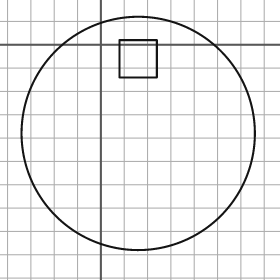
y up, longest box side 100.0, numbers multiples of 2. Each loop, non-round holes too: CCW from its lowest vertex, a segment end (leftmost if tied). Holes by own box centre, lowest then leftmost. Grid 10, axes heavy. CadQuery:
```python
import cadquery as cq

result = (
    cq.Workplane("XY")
    .moveTo(16.0, -38.0)
    .circle(50.0)
    .moveTo(8.0, -14.0)
    .lineTo(24.0, -14.0)
    .lineTo(24.0, 2.0)
    .lineTo(8.0, 2.0)
    .close()
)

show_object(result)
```